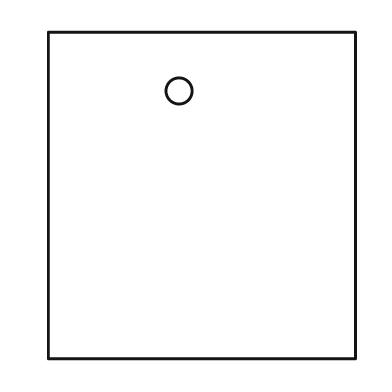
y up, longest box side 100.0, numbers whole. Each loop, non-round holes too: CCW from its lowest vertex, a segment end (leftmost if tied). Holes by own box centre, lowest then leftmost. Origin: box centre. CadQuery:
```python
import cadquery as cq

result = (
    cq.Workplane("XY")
    .moveTo(-47.0, -50.0)
    .lineTo(47.0, -50.0)
    .lineTo(47.0, 50.0)
    .lineTo(-47.0, 50.0)
    .close()
    .moveTo(-7.0, 32.0)
    .circle(4.0)
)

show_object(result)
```